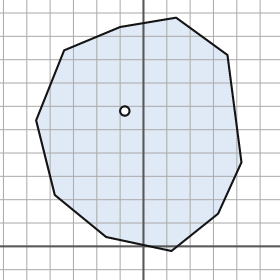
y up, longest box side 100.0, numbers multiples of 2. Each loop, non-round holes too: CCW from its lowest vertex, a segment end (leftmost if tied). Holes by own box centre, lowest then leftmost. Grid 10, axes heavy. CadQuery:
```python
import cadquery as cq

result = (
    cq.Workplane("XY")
    .moveTo(12.0, -2.0)
    .lineTo(32.0, 14.0)
    .lineTo(42.0, 36.0)
    .lineTo(36.0, 82.0)
    .lineTo(14.0, 98.0)
    .lineTo(-10.0, 94.0)
    .lineTo(-34.0, 84.0)
    .lineTo(-46.0, 54.0)
    .lineTo(-38.0, 22.0)
    .lineTo(-16.0, 4.0)
    .close()
    .moveTo(-8.0, 58.0)
    .circle(2.0)
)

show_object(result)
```